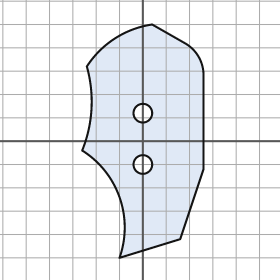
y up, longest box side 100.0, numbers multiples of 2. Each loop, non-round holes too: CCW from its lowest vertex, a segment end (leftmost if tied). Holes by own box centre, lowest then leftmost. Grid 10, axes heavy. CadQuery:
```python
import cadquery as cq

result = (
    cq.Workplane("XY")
    .moveTo(-10.0, -50.0)
    .lineTo(16.0, -42.0)
    .lineTo(26.0, -12.0)
    .lineTo(26.0, 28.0)
    .threePointArc((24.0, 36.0), (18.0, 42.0))
    .lineTo(4.0, 50.0)
    .threePointArc((-12.0, 44.0), (-24.0, 32.0))
    .threePointArc((-22.0, 14.0), (-26.0, -4.0))
    .threePointArc((-10.0, -24.0), (-10.0, -50.0))
    .close()
    .moveTo(0.0, -10.0)
    .circle(4.0)
    .moveTo(0.0, 12.0)
    .circle(4.0)
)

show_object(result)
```